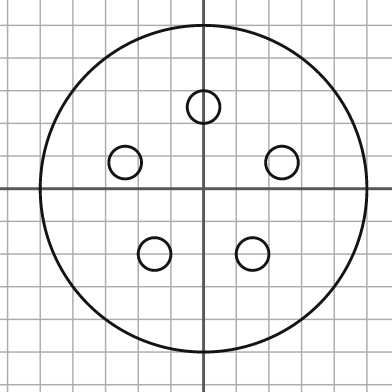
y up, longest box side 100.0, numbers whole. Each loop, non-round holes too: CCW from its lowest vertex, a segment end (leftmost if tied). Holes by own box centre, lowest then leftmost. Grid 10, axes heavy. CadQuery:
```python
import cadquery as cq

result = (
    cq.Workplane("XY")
    .moveTo(0.0, 0.0)
    .circle(50.0)
    .moveTo(-15.0, -20.0)
    .circle(5.0)
    .moveTo(15.0, -20.0)
    .circle(5.0)
    .moveTo(-24.0, 8.0)
    .circle(5.0)
    .moveTo(24.0, 8.0)
    .circle(5.0)
    .moveTo(0.0, 25.0)
    .circle(5.0)
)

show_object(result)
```